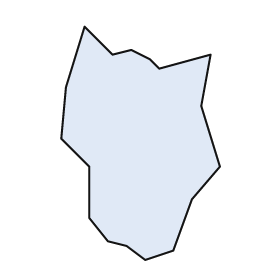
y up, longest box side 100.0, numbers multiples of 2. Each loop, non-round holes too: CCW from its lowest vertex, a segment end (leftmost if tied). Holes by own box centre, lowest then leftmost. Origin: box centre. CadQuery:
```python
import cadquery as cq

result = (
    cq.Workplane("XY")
    .moveTo(2.0, -50.0)
    .lineTo(14.0, -46.0)
    .lineTo(22.0, -24.0)
    .lineTo(34.0, -10.0)
    .lineTo(26.0, 16.0)
    .lineTo(30.0, 38.0)
    .lineTo(8.0, 32.0)
    .lineTo(4.0, 36.0)
    .lineTo(-4.0, 40.0)
    .lineTo(-12.0, 38.0)
    .lineTo(-24.0, 50.0)
    .lineTo(-32.0, 24.0)
    .lineTo(-34.0, 2.0)
    .lineTo(-22.0, -10.0)
    .lineTo(-22.0, -32.0)
    .lineTo(-14.0, -42.0)
    .lineTo(-6.0, -44.0)
    .close()
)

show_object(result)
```